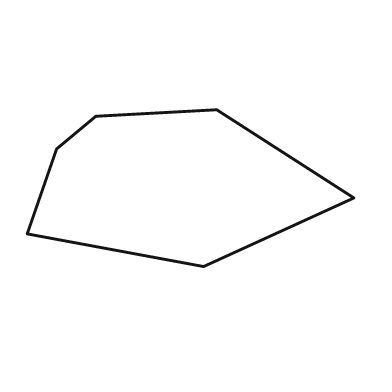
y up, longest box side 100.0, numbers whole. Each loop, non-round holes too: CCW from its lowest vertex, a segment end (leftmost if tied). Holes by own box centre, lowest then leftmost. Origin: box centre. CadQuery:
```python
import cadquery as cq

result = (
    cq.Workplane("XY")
    .moveTo(4.0, -24.0)
    .lineTo(50.0, -3.0)
    .lineTo(8.0, 24.0)
    .lineTo(-29.0, 22.0)
    .lineTo(-41.0, 12.0)
    .lineTo(-50.0, -14.0)
    .close()
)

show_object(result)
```